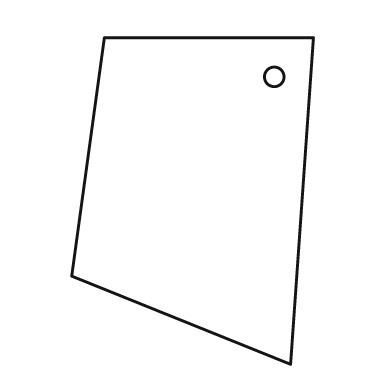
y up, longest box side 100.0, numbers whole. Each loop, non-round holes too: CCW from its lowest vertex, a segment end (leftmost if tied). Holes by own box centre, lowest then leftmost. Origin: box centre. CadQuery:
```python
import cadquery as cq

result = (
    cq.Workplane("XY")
    .moveTo(30.0, -50.0)
    .lineTo(37.0, 50.0)
    .lineTo(-27.0, 50.0)
    .lineTo(-37.0, -23.0)
    .close()
    .moveTo(25.0, 38.0)
    .circle(3.0)
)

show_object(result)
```